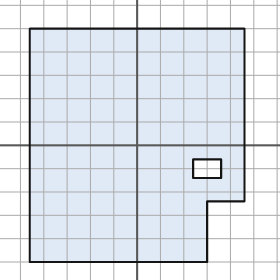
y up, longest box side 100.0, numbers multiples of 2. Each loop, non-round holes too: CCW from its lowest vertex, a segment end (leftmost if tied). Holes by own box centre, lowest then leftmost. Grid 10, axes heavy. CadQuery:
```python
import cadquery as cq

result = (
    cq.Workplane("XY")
    .moveTo(-46.0, -50.0)
    .lineTo(30.0, -50.0)
    .lineTo(30.0, -24.0)
    .lineTo(46.0, -24.0)
    .lineTo(46.0, 50.0)
    .lineTo(-46.0, 50.0)
    .close()
    .moveTo(24.0, -14.0)
    .lineTo(36.0, -14.0)
    .lineTo(36.0, -6.0)
    .lineTo(24.0, -6.0)
    .close()
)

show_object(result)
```